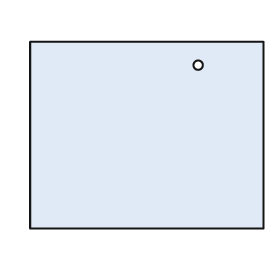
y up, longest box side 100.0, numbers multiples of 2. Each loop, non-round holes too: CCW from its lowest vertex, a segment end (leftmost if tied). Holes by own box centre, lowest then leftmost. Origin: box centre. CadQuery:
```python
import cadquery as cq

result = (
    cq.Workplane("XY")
    .moveTo(-50.0, -40.0)
    .lineTo(50.0, -40.0)
    .lineTo(50.0, 40.0)
    .lineTo(-50.0, 40.0)
    .close()
    .moveTo(22.0, 30.0)
    .circle(2.0)
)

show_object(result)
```